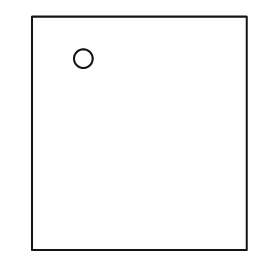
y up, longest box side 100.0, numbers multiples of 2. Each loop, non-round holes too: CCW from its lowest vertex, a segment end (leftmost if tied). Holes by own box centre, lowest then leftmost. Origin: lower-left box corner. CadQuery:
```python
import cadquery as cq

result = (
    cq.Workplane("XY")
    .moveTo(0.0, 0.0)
    .lineTo(92.0, 0.0)
    .lineTo(92.0, 100.0)
    .lineTo(0.0, 100.0)
    .close()
    .moveTo(22.0, 82.0)
    .circle(4.0)
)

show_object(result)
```